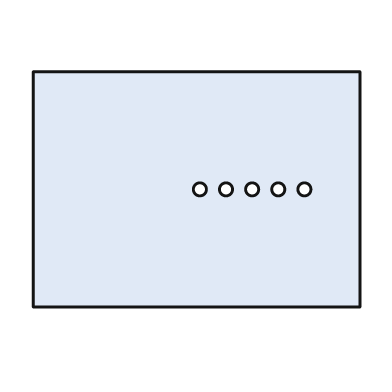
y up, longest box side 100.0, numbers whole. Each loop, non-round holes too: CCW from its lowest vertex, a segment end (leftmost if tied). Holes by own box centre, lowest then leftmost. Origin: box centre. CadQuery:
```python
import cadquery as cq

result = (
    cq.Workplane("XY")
    .moveTo(-50.0, -36.0)
    .lineTo(50.0, -36.0)
    .lineTo(50.0, 36.0)
    .lineTo(-50.0, 36.0)
    .close()
    .moveTo(1.0, 0.0)
    .circle(2.0)
    .moveTo(9.0, 0.0)
    .circle(2.0)
    .moveTo(17.0, 0.0)
    .circle(2.0)
    .moveTo(25.0, 0.0)
    .circle(2.0)
    .moveTo(33.0, 0.0)
    .circle(2.0)
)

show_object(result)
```